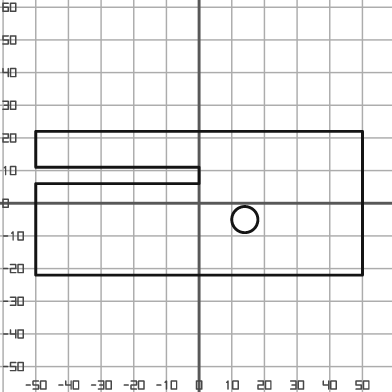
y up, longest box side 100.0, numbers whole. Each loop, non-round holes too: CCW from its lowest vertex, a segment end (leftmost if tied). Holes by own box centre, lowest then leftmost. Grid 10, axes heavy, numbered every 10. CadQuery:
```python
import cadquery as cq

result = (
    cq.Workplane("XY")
    .moveTo(-50.0, -22.0)
    .lineTo(50.0, -22.0)
    .lineTo(50.0, 22.0)
    .lineTo(-50.0, 22.0)
    .lineTo(-50.0, 11.0)
    .lineTo(0.0, 11.0)
    .lineTo(0.0, 6.0)
    .lineTo(-50.0, 6.0)
    .close()
    .moveTo(14.0, -5.0)
    .circle(4.0)
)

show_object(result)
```